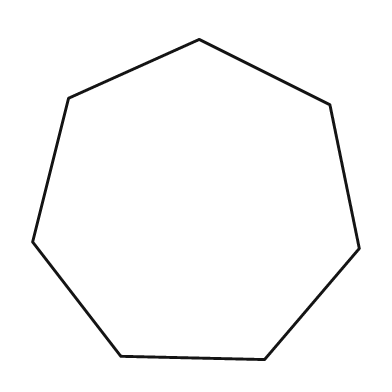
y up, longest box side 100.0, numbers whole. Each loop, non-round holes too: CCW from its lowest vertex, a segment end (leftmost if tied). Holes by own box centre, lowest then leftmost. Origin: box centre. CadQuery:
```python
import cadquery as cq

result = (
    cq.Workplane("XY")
    .moveTo(21.0, -49.0)
    .lineTo(50.0, -15.0)
    .lineTo(41.0, 29.0)
    .lineTo(1.0, 49.0)
    .lineTo(-39.0, 31.0)
    .lineTo(-50.0, -13.0)
    .lineTo(-23.0, -48.0)
    .close()
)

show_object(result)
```